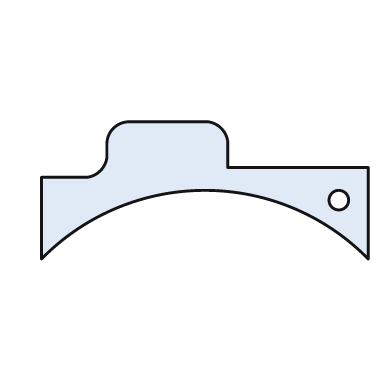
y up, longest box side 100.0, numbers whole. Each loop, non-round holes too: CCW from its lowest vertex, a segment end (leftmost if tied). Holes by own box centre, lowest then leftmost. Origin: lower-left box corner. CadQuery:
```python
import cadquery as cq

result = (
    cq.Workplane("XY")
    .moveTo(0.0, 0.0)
    .threePointArc((50.0, 21.0), (100.0, 0.0))
    .lineTo(100.0, 28.0)
    .lineTo(57.0, 28.0)
    .lineTo(57.0, 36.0)
    .threePointArc((55.0, 40.0), (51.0, 42.0))
    .lineTo(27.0, 42.0)
    .threePointArc((22.0, 40.0), (20.0, 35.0))
    .lineTo(20.0, 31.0)
    .threePointArc((18.0, 27.0), (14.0, 25.0))
    .lineTo(0.0, 25.0)
    .close()
    .moveTo(91.0, 18.0)
    .circle(3.0)
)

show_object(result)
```